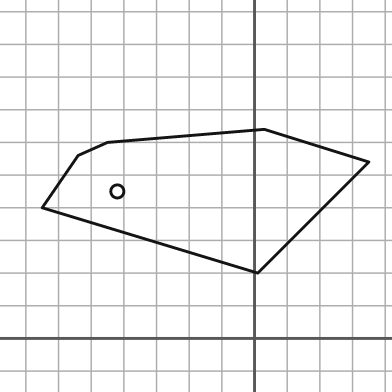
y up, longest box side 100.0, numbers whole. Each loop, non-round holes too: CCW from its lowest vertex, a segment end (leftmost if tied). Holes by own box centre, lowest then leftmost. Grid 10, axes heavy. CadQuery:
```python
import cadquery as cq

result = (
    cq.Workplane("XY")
    .moveTo(1.0, 20.0)
    .lineTo(35.0, 54.0)
    .lineTo(3.0, 64.0)
    .lineTo(-45.0, 60.0)
    .lineTo(-54.0, 56.0)
    .lineTo(-65.0, 40.0)
    .close()
    .moveTo(-42.0, 45.0)
    .circle(2.0)
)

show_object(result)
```